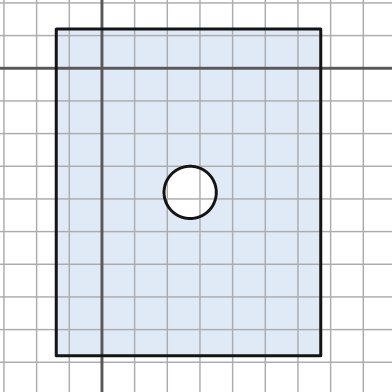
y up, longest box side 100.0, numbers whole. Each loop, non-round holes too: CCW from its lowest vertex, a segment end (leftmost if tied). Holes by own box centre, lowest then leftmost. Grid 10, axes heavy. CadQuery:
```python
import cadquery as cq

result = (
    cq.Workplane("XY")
    .moveTo(-14.0, -88.0)
    .lineTo(67.0, -88.0)
    .lineTo(67.0, 12.0)
    .lineTo(-14.0, 12.0)
    .close()
    .moveTo(27.0, -38.0)
    .circle(8.0)
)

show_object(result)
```